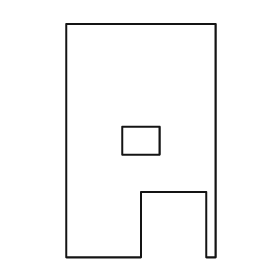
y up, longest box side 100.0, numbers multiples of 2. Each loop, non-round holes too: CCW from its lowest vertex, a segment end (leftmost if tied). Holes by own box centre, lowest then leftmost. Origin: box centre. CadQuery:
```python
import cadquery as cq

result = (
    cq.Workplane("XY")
    .moveTo(-32.0, -50.0)
    .lineTo(0.0, -50.0)
    .lineTo(0.0, -22.0)
    .lineTo(28.0, -22.0)
    .lineTo(28.0, -50.0)
    .lineTo(32.0, -50.0)
    .lineTo(32.0, 50.0)
    .lineTo(-32.0, 50.0)
    .close()
    .moveTo(-8.0, -6.0)
    .lineTo(8.0, -6.0)
    .lineTo(8.0, 6.0)
    .lineTo(-8.0, 6.0)
    .close()
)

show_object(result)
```